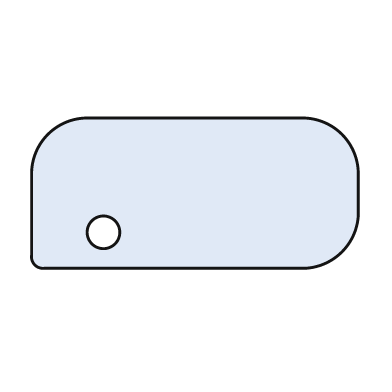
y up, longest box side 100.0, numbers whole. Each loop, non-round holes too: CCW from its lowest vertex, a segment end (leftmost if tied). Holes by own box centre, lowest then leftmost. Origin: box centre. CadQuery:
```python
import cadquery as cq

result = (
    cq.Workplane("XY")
    .moveTo(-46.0, -23.0)
    .lineTo(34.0, -23.0)
    .threePointArc((45.0, -18.0), (50.0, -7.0))
    .lineTo(50.0, 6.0)
    .threePointArc((45.0, 18.0), (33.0, 23.0))
    .lineTo(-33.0, 23.0)
    .threePointArc((-45.0, 18.0), (-50.0, 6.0))
    .lineTo(-50.0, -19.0)
    .threePointArc((-49.0, -22.0), (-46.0, -23.0))
    .close()
    .moveTo(-28.0, -12.0)
    .circle(5.0)
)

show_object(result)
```